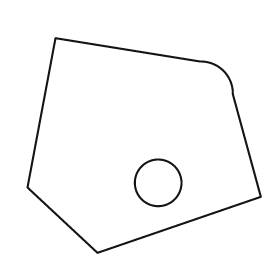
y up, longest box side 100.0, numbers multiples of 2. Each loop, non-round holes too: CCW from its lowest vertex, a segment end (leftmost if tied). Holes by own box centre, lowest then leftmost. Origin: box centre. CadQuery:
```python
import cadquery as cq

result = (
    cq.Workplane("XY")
    .moveTo(-20.0, -46.0)
    .lineTo(50.0, -22.0)
    .lineTo(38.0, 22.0)
    .threePointArc((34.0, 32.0), (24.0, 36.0))
    .lineTo(-38.0, 46.0)
    .lineTo(-50.0, -18.0)
    .close()
    .moveTo(6.0, -16.0)
    .circle(10.0)
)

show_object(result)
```